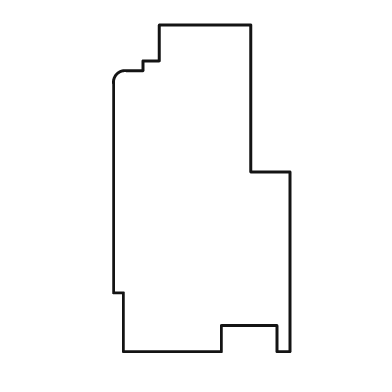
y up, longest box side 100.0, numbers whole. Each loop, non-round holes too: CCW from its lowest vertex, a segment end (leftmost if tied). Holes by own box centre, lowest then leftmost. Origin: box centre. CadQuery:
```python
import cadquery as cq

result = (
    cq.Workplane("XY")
    .moveTo(-24.0, -50.0)
    .lineTo(6.0, -50.0)
    .lineTo(6.0, -42.0)
    .lineTo(23.0, -42.0)
    .lineTo(23.0, -50.0)
    .lineTo(27.0, -50.0)
    .lineTo(27.0, 5.0)
    .lineTo(15.0, 5.0)
    .lineTo(15.0, 50.0)
    .lineTo(-13.0, 50.0)
    .lineTo(-13.0, 39.0)
    .lineTo(-18.0, 39.0)
    .lineTo(-18.0, 36.0)
    .lineTo(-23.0, 36.0)
    .threePointArc((-26.0, 35.0), (-27.0, 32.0))
    .lineTo(-27.0, -32.0)
    .lineTo(-24.0, -32.0)
    .close()
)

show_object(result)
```